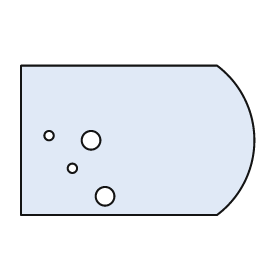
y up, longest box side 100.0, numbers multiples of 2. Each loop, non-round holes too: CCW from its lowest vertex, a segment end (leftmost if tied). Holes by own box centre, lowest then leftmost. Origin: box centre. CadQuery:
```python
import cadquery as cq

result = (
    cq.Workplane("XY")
    .moveTo(-50.0, -32.0)
    .lineTo(34.0, -32.0)
    .threePointArc((50.0, 0.0), (34.0, 32.0))
    .lineTo(-50.0, 32.0)
    .close()
    .moveTo(-14.0, -24.0)
    .circle(4.0)
    .moveTo(-28.0, -12.0)
    .circle(2.0)
    .moveTo(-20.0, 0.0)
    .circle(4.0)
    .moveTo(-38.0, 2.0)
    .circle(2.0)
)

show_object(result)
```